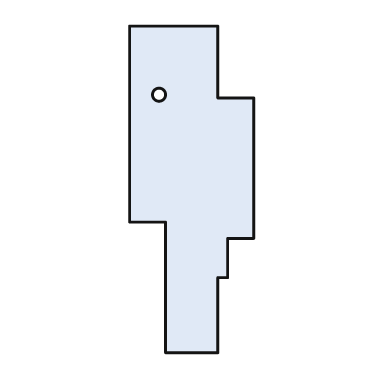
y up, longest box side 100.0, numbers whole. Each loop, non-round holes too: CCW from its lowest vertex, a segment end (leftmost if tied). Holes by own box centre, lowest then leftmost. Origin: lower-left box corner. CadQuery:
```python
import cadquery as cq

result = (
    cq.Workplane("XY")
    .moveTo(11.0, 0.0)
    .lineTo(27.0, 0.0)
    .lineTo(27.0, 23.0)
    .lineTo(30.0, 23.0)
    .lineTo(30.0, 35.0)
    .lineTo(38.0, 35.0)
    .lineTo(38.0, 78.0)
    .lineTo(27.0, 78.0)
    .lineTo(27.0, 100.0)
    .lineTo(0.0, 100.0)
    .lineTo(0.0, 40.0)
    .lineTo(11.0, 40.0)
    .close()
    .moveTo(9.0, 79.0)
    .circle(2.0)
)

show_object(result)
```